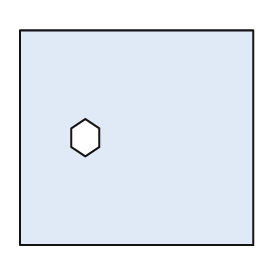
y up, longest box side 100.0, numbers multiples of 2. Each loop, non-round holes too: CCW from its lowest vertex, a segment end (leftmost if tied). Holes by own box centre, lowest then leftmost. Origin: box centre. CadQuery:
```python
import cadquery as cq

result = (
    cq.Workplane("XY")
    .moveTo(-50.0, -46.0)
    .lineTo(50.0, -46.0)
    .lineTo(50.0, 46.0)
    .lineTo(-50.0, 46.0)
    .close()
    .moveTo(-22.0, -8.0)
    .lineTo(-16.0, -4.0)
    .lineTo(-16.0, 4.0)
    .lineTo(-22.0, 8.0)
    .lineTo(-28.0, 4.0)
    .lineTo(-28.0, -4.0)
    .close()
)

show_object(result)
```